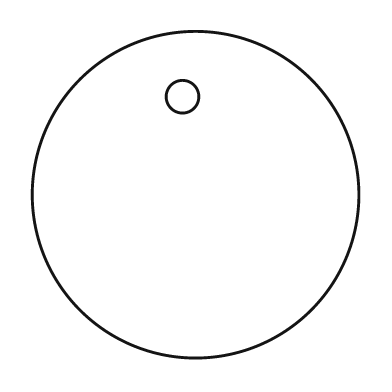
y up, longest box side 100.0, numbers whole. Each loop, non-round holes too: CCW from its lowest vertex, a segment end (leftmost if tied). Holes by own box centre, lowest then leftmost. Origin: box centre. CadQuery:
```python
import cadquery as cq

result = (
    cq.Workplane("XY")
    .moveTo(0.0, 0.0)
    .circle(50.0)
    .moveTo(-4.0, 30.0)
    .circle(5.0)
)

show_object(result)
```